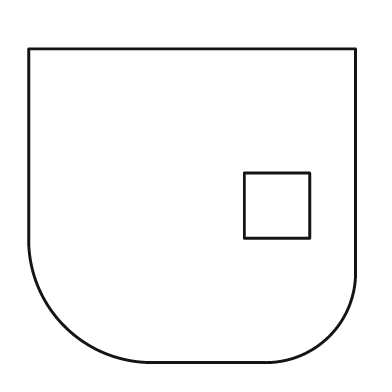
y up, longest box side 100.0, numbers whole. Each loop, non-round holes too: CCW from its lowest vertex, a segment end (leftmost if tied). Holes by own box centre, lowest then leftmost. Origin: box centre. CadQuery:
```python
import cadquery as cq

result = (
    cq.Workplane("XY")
    .moveTo(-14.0, -48.0)
    .lineTo(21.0, -48.0)
    .threePointArc((42.0, -40.0), (50.0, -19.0))
    .lineTo(50.0, 48.0)
    .lineTo(-50.0, 48.0)
    .lineTo(-50.0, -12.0)
    .threePointArc((-39.0, -37.0), (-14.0, -48.0))
    .close()
    .moveTo(16.0, -10.0)
    .lineTo(36.0, -10.0)
    .lineTo(36.0, 10.0)
    .lineTo(16.0, 10.0)
    .close()
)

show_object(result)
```